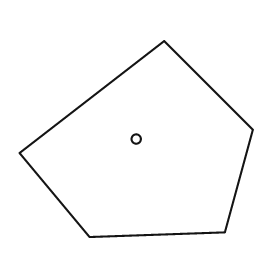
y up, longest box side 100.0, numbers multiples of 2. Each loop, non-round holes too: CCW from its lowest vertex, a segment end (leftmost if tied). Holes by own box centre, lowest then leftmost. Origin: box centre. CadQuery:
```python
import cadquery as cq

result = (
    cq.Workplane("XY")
    .moveTo(-20.0, -42.0)
    .lineTo(38.0, -40.0)
    .lineTo(50.0, 4.0)
    .lineTo(12.0, 42.0)
    .lineTo(-50.0, -6.0)
    .close()
    .moveTo(0.0, 0.0)
    .circle(2.0)
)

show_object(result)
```